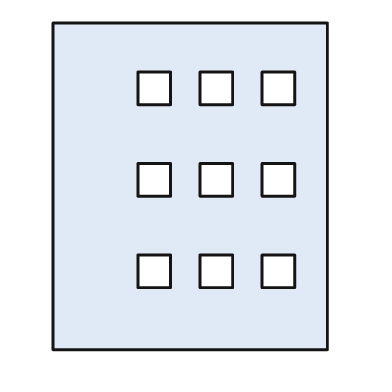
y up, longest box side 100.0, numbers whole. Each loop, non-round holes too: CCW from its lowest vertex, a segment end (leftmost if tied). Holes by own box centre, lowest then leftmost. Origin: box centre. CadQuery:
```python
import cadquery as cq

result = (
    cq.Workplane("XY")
    .moveTo(-42.0, -50.0)
    .lineTo(42.0, -50.0)
    .lineTo(42.0, 50.0)
    .lineTo(-42.0, 50.0)
    .close()
    .moveTo(-16.0, -31.0)
    .lineTo(-6.0, -31.0)
    .lineTo(-6.0, -21.0)
    .lineTo(-16.0, -21.0)
    .close()
    .moveTo(3.0, -31.0)
    .lineTo(13.0, -31.0)
    .lineTo(13.0, -21.0)
    .lineTo(3.0, -21.0)
    .close()
    .moveTo(22.0, -31.0)
    .lineTo(32.0, -31.0)
    .lineTo(32.0, -21.0)
    .lineTo(22.0, -21.0)
    .close()
    .moveTo(-16.0, -3.0)
    .lineTo(-6.0, -3.0)
    .lineTo(-6.0, 7.0)
    .lineTo(-16.0, 7.0)
    .close()
    .moveTo(3.0, -3.0)
    .lineTo(13.0, -3.0)
    .lineTo(13.0, 7.0)
    .lineTo(3.0, 7.0)
    .close()
    .moveTo(22.0, -3.0)
    .lineTo(32.0, -3.0)
    .lineTo(32.0, 7.0)
    .lineTo(22.0, 7.0)
    .close()
    .moveTo(-16.0, 25.0)
    .lineTo(-6.0, 25.0)
    .lineTo(-6.0, 35.0)
    .lineTo(-16.0, 35.0)
    .close()
    .moveTo(3.0, 25.0)
    .lineTo(13.0, 25.0)
    .lineTo(13.0, 35.0)
    .lineTo(3.0, 35.0)
    .close()
    .moveTo(22.0, 25.0)
    .lineTo(32.0, 25.0)
    .lineTo(32.0, 35.0)
    .lineTo(22.0, 35.0)
    .close()
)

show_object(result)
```